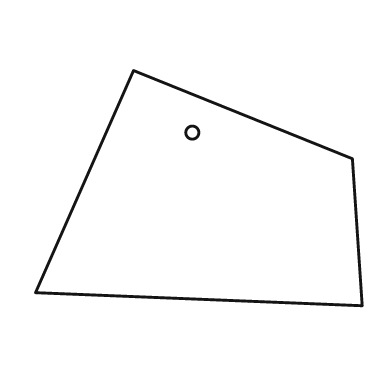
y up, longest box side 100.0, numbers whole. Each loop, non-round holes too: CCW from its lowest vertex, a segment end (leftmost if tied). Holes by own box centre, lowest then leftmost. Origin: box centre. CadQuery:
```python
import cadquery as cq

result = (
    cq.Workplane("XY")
    .moveTo(50.0, -36.0)
    .lineTo(47.0, 9.0)
    .lineTo(-20.0, 36.0)
    .lineTo(-50.0, -32.0)
    .close()
    .moveTo(-2.0, 17.0)
    .circle(2.0)
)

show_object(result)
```